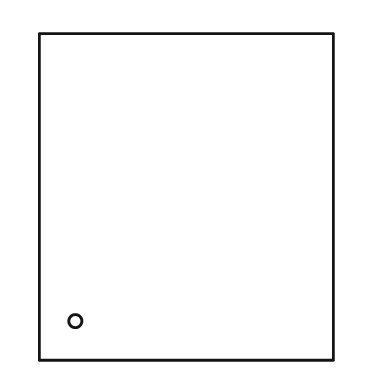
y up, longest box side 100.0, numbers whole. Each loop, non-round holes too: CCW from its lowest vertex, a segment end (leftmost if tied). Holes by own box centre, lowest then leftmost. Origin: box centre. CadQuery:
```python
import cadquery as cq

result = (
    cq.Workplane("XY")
    .moveTo(-45.0, -50.0)
    .lineTo(45.0, -50.0)
    .lineTo(45.0, 50.0)
    .lineTo(-45.0, 50.0)
    .close()
    .moveTo(-34.0, -38.0)
    .circle(2.0)
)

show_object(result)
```